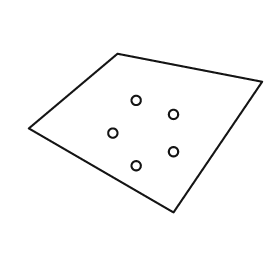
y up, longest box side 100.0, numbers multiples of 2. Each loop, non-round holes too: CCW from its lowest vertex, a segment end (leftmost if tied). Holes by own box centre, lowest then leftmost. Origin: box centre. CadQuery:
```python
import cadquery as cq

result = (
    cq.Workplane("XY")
    .moveTo(12.0, -34.0)
    .lineTo(50.0, 22.0)
    .lineTo(-12.0, 34.0)
    .lineTo(-50.0, 2.0)
    .close()
    .moveTo(-4.0, -14.0)
    .circle(2.0)
    .moveTo(12.0, -8.0)
    .circle(2.0)
    .moveTo(-14.0, 0.0)
    .circle(2.0)
    .moveTo(12.0, 8.0)
    .circle(2.0)
    .moveTo(-4.0, 14.0)
    .circle(2.0)
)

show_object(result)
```